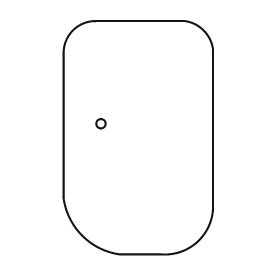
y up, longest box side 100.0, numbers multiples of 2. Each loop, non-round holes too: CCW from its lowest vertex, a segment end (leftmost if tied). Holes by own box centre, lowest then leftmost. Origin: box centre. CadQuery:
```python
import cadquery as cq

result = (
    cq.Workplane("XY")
    .moveTo(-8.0, -50.0)
    .lineTo(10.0, -50.0)
    .threePointArc((26.0, -44.0), (32.0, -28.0))
    .lineTo(32.0, 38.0)
    .threePointArc((28.0, 46.0), (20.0, 50.0))
    .lineTo(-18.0, 50.0)
    .threePointArc((-28.0, 46.0), (-32.0, 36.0))
    .lineTo(-32.0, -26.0)
    .threePointArc((-24.0, -42.0), (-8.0, -50.0))
    .close()
    .moveTo(-16.0, 6.0)
    .circle(2.0)
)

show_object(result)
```